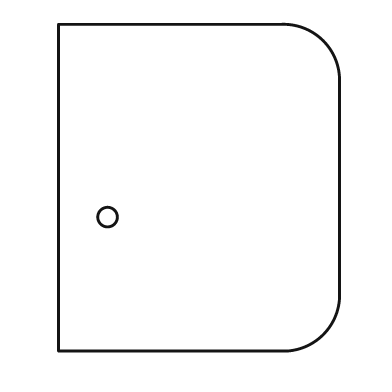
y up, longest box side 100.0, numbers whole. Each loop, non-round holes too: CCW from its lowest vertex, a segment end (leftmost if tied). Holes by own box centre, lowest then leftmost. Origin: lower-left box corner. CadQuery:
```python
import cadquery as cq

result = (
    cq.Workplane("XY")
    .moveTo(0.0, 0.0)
    .lineTo(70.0, 0.0)
    .threePointArc((81.0, 5.0), (86.0, 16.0))
    .lineTo(86.0, 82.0)
    .threePointArc((81.0, 95.0), (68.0, 100.0))
    .lineTo(0.0, 100.0)
    .close()
    .moveTo(15.0, 41.0)
    .circle(3.0)
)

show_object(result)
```